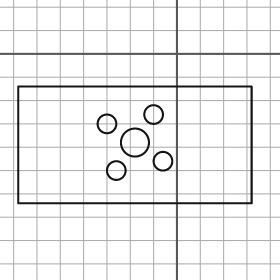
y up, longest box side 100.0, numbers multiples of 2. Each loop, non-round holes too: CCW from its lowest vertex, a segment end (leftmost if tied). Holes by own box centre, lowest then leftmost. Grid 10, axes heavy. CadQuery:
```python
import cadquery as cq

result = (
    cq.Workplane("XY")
    .moveTo(-68.0, -64.0)
    .lineTo(32.0, -64.0)
    .lineTo(32.0, -14.0)
    .lineTo(-68.0, -14.0)
    .close()
    .moveTo(-26.0, -50.0)
    .circle(4.0)
    .moveTo(-6.0, -46.0)
    .circle(4.0)
    .moveTo(-18.0, -38.0)
    .circle(6.0)
    .moveTo(-30.0, -30.0)
    .circle(4.0)
    .moveTo(-10.0, -26.0)
    .circle(4.0)
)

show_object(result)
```